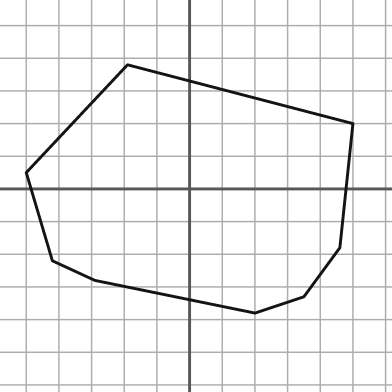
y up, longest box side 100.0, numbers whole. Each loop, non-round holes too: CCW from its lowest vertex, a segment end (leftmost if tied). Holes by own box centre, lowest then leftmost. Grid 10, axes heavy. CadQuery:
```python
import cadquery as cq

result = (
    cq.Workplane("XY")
    .moveTo(20.0, -38.0)
    .lineTo(35.0, -33.0)
    .lineTo(46.0, -18.0)
    .lineTo(50.0, 20.0)
    .lineTo(-19.0, 38.0)
    .lineTo(-50.0, 5.0)
    .lineTo(-42.0, -22.0)
    .lineTo(-29.0, -28.0)
    .close()
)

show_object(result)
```